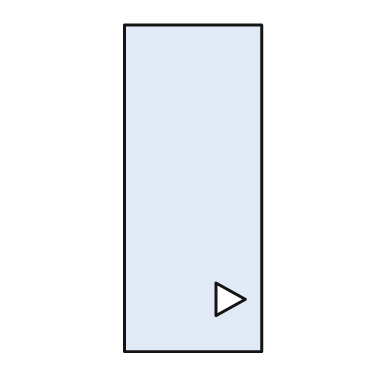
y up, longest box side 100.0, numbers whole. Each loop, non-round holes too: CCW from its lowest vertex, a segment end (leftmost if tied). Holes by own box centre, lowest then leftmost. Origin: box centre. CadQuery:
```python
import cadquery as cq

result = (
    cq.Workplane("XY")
    .moveTo(-21.0, -50.0)
    .lineTo(21.0, -50.0)
    .lineTo(21.0, 50.0)
    .lineTo(-21.0, 50.0)
    .close()
    .moveTo(7.0, -39.0)
    .lineTo(16.0, -34.0)
    .lineTo(7.0, -29.0)
    .close()
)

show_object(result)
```